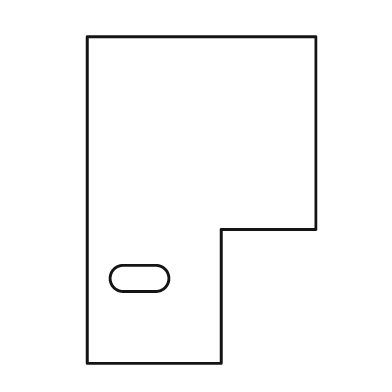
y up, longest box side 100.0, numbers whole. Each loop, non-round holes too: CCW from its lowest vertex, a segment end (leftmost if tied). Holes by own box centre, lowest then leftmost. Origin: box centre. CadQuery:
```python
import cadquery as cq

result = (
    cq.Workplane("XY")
    .moveTo(-35.0, -50.0)
    .lineTo(6.0, -50.0)
    .lineTo(6.0, -9.0)
    .lineTo(35.0, -9.0)
    .lineTo(35.0, 50.0)
    .lineTo(-35.0, 50.0)
    .close()
    .moveTo(-24.0, -28.0)
    .lineTo(-14.0, -28.0)
    .threePointArc((-10.0, -24.0), (-14.0, -20.0))
    .lineTo(-24.0, -20.0)
    .threePointArc((-28.0, -24.0), (-24.0, -28.0))
    .close()
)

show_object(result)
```